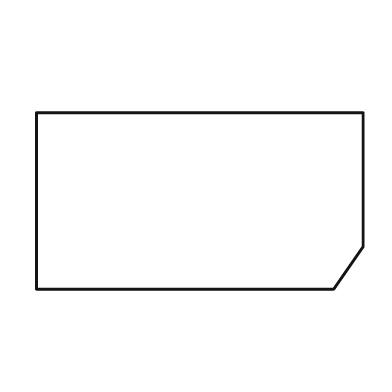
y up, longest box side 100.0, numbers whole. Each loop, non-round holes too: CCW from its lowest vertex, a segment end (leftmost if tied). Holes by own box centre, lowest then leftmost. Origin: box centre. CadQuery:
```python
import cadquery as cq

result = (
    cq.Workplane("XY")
    .moveTo(-50.0, -27.0)
    .lineTo(41.0, -27.0)
    .lineTo(50.0, -14.0)
    .lineTo(50.0, 27.0)
    .lineTo(-50.0, 27.0)
    .close()
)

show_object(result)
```